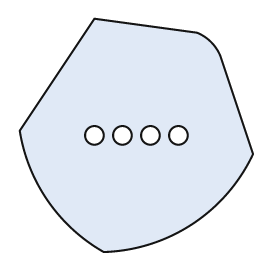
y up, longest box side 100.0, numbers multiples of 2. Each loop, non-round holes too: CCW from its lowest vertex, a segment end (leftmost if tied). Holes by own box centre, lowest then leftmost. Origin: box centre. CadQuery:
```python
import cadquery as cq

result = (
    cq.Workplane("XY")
    .moveTo(-14.0, -50.0)
    .threePointArc((24.0, -38.0), (50.0, -8.0))
    .lineTo(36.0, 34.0)
    .threePointArc((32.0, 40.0), (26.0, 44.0))
    .lineTo(-18.0, 50.0)
    .lineTo(-50.0, 2.0)
    .threePointArc((-38.0, -28.0), (-14.0, -50.0))
    .close()
    .moveTo(-18.0, 0.0)
    .circle(4.0)
    .moveTo(-6.0, 0.0)
    .circle(4.0)
    .moveTo(6.0, 0.0)
    .circle(4.0)
    .moveTo(18.0, 0.0)
    .circle(4.0)
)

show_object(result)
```